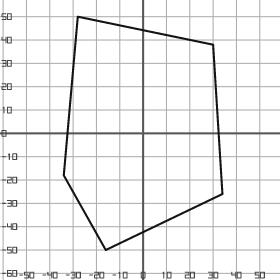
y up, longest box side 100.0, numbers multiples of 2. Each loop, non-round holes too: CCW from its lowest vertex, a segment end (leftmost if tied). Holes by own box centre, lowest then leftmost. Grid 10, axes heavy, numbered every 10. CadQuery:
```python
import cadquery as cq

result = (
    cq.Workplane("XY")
    .moveTo(-16.0, -50.0)
    .lineTo(34.0, -26.0)
    .lineTo(30.0, 38.0)
    .lineTo(-28.0, 50.0)
    .lineTo(-34.0, -18.0)
    .close()
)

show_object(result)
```